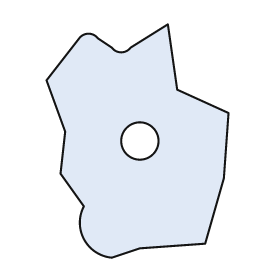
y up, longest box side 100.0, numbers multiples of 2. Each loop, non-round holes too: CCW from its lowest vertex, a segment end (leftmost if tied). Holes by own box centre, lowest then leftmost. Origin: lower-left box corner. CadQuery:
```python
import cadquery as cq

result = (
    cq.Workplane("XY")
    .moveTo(28.0, 0.0)
    .lineTo(40.0, 4.0)
    .lineTo(68.0, 6.0)
    .lineTo(76.0, 34.0)
    .lineTo(78.0, 62.0)
    .lineTo(56.0, 72.0)
    .lineTo(52.0, 100.0)
    .lineTo(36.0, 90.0)
    .threePointArc((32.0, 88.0), (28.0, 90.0))
    .lineTo(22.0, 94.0)
    .threePointArc((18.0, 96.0), (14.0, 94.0))
    .lineTo(0.0, 76.0)
    .lineTo(8.0, 54.0)
    .lineTo(6.0, 36.0)
    .lineTo(16.0, 22.0)
    .threePointArc((16.0, 8.0), (28.0, 0.0))
    .close()
    .moveTo(40.0, 50.0)
    .circle(8.0)
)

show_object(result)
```